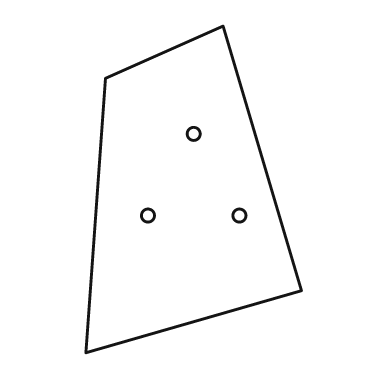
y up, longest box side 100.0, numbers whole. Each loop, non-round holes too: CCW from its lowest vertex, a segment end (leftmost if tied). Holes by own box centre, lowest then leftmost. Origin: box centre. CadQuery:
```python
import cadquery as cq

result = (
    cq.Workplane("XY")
    .moveTo(-33.0, -50.0)
    .lineTo(33.0, -31.0)
    .lineTo(9.0, 50.0)
    .lineTo(-27.0, 34.0)
    .close()
    .moveTo(-14.0, -8.0)
    .circle(2.0)
    .moveTo(14.0, -8.0)
    .circle(2.0)
    .moveTo(0.0, 17.0)
    .circle(2.0)
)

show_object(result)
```